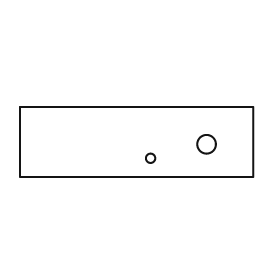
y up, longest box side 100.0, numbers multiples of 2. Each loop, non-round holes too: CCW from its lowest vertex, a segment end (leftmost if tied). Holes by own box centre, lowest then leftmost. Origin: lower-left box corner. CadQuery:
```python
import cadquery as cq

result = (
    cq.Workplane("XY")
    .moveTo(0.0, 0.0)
    .lineTo(100.0, 0.0)
    .lineTo(100.0, 30.0)
    .lineTo(0.0, 30.0)
    .close()
    .moveTo(56.0, 8.0)
    .circle(2.0)
    .moveTo(80.0, 14.0)
    .circle(4.0)
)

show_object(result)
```